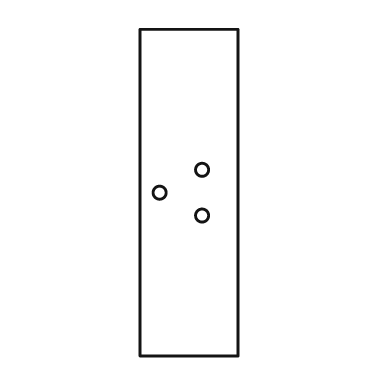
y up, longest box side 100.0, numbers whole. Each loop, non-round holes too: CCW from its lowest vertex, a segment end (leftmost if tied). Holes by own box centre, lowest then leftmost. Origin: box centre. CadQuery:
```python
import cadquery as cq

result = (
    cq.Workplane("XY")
    .moveTo(-15.0, -50.0)
    .lineTo(15.0, -50.0)
    .lineTo(15.0, 50.0)
    .lineTo(-15.0, 50.0)
    .close()
    .moveTo(4.0, -7.0)
    .circle(2.0)
    .moveTo(-9.0, 0.0)
    .circle(2.0)
    .moveTo(4.0, 7.0)
    .circle(2.0)
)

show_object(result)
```